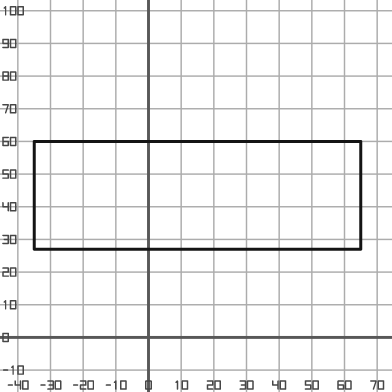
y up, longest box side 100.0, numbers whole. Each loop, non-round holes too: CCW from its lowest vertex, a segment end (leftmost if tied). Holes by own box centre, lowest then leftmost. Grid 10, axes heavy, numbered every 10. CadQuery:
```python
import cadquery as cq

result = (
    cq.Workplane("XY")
    .moveTo(-35.0, 27.0)
    .lineTo(65.0, 27.0)
    .lineTo(65.0, 60.0)
    .lineTo(-35.0, 60.0)
    .close()
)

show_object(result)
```